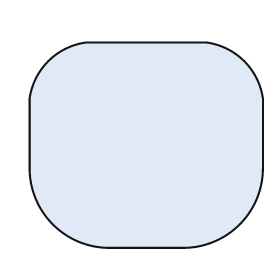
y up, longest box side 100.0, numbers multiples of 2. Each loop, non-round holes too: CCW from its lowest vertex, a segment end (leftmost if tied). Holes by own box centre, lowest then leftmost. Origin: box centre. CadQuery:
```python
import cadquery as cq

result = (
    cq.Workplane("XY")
    .moveTo(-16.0, -44.0)
    .lineTo(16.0, -44.0)
    .threePointArc((40.0, -34.0), (50.0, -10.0))
    .lineTo(50.0, 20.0)
    .threePointArc((42.0, 36.0), (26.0, 44.0))
    .lineTo(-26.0, 44.0)
    .threePointArc((-42.0, 36.0), (-50.0, 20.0))
    .lineTo(-50.0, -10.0)
    .threePointArc((-40.0, -34.0), (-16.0, -44.0))
    .close()
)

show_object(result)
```